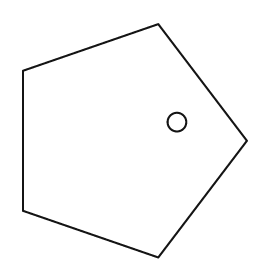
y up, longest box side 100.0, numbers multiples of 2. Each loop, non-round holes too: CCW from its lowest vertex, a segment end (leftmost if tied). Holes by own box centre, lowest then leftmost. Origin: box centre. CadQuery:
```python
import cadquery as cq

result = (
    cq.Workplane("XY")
    .moveTo(10.0, -50.0)
    .lineTo(48.0, 0.0)
    .lineTo(10.0, 50.0)
    .lineTo(-48.0, 30.0)
    .lineTo(-48.0, -30.0)
    .close()
    .moveTo(18.0, 8.0)
    .circle(4.0)
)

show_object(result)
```